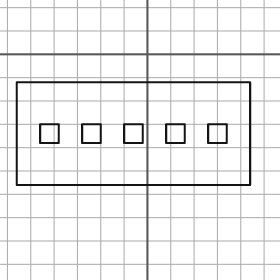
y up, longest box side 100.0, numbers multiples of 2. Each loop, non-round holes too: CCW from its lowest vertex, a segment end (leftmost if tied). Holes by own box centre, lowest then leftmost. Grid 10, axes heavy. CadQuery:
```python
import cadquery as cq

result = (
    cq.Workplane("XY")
    .moveTo(-56.0, -56.0)
    .lineTo(44.0, -56.0)
    .lineTo(44.0, -12.0)
    .lineTo(-56.0, -12.0)
    .close()
    .moveTo(-46.0, -38.0)
    .lineTo(-38.0, -38.0)
    .lineTo(-38.0, -30.0)
    .lineTo(-46.0, -30.0)
    .close()
    .moveTo(-28.0, -38.0)
    .lineTo(-20.0, -38.0)
    .lineTo(-20.0, -30.0)
    .lineTo(-28.0, -30.0)
    .close()
    .moveTo(-10.0, -38.0)
    .lineTo(-2.0, -38.0)
    .lineTo(-2.0, -30.0)
    .lineTo(-10.0, -30.0)
    .close()
    .moveTo(8.0, -38.0)
    .lineTo(16.0, -38.0)
    .lineTo(16.0, -30.0)
    .lineTo(8.0, -30.0)
    .close()
    .moveTo(26.0, -38.0)
    .lineTo(34.0, -38.0)
    .lineTo(34.0, -30.0)
    .lineTo(26.0, -30.0)
    .close()
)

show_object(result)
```